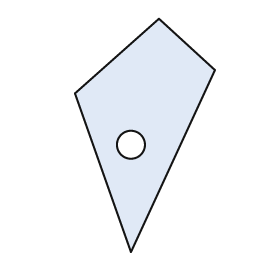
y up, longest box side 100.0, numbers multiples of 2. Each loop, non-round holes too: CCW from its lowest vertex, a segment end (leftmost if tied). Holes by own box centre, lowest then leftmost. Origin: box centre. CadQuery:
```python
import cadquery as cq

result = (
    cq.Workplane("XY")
    .moveTo(-6.0, -50.0)
    .lineTo(30.0, 28.0)
    .lineTo(6.0, 50.0)
    .lineTo(-30.0, 18.0)
    .close()
    .moveTo(-6.0, -4.0)
    .circle(6.0)
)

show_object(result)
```